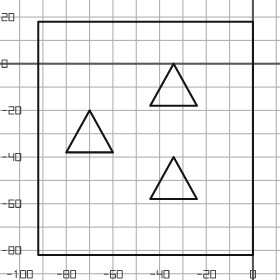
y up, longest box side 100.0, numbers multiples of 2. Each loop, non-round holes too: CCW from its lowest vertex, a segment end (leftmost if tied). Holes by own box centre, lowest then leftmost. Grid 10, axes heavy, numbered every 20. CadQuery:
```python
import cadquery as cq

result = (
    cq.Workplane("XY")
    .moveTo(-92.0, -82.0)
    .lineTo(0.0, -82.0)
    .lineTo(0.0, 18.0)
    .lineTo(-92.0, 18.0)
    .close()
    .moveTo(-44.0, -58.0)
    .lineTo(-24.0, -58.0)
    .lineTo(-34.0, -40.0)
    .close()
    .moveTo(-80.0, -38.0)
    .lineTo(-60.0, -38.0)
    .lineTo(-70.0, -20.0)
    .close()
    .moveTo(-44.0, -18.0)
    .lineTo(-24.0, -18.0)
    .lineTo(-34.0, 0.0)
    .close()
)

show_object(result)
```